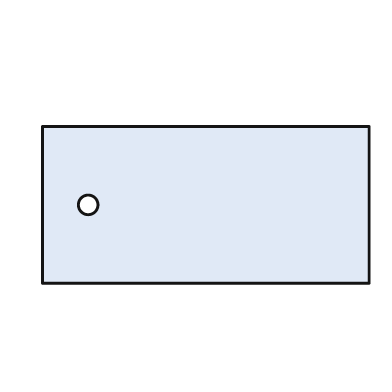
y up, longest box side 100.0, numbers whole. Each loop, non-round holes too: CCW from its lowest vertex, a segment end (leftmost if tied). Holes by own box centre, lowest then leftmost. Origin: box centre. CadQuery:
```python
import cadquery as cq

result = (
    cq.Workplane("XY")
    .moveTo(-50.0, -24.0)
    .lineTo(50.0, -24.0)
    .lineTo(50.0, 24.0)
    .lineTo(-50.0, 24.0)
    .close()
    .moveTo(-36.0, 0.0)
    .circle(3.0)
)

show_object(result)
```